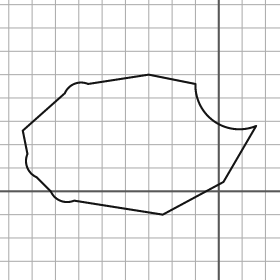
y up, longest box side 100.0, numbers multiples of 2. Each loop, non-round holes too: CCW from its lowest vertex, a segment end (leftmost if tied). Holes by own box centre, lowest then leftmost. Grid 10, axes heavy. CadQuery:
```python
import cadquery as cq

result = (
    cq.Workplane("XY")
    .moveTo(-24.0, -10.0)
    .lineTo(2.0, 4.0)
    .lineTo(16.0, 28.0)
    .threePointArc((-2.0, 30.0), (-10.0, 46.0))
    .lineTo(-30.0, 50.0)
    .lineTo(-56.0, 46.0)
    .threePointArc((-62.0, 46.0), (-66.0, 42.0))
    .lineTo(-84.0, 26.0)
    .lineTo(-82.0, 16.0)
    .threePointArc((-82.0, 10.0), (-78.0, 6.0))
    .lineTo(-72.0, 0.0)
    .threePointArc((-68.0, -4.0), (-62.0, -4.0))
    .close()
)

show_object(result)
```